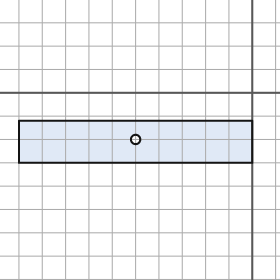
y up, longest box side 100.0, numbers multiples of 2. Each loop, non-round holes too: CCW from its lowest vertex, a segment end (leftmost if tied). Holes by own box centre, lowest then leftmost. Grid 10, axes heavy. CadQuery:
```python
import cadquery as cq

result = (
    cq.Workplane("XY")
    .moveTo(-100.0, -30.0)
    .lineTo(0.0, -30.0)
    .lineTo(0.0, -12.0)
    .lineTo(-100.0, -12.0)
    .close()
    .moveTo(-50.0, -20.0)
    .circle(2.0)
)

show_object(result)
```